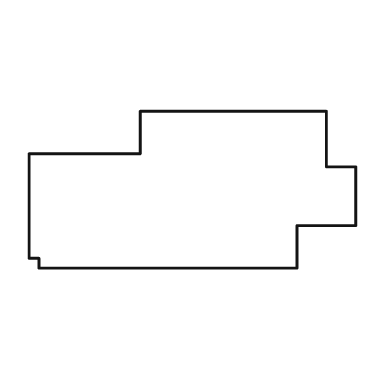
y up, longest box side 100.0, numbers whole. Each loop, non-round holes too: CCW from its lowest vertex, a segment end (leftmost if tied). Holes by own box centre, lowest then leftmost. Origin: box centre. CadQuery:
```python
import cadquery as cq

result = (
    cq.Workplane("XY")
    .moveTo(-47.0, -24.0)
    .lineTo(32.0, -24.0)
    .lineTo(32.0, -11.0)
    .lineTo(50.0, -11.0)
    .lineTo(50.0, 7.0)
    .lineTo(41.0, 7.0)
    .lineTo(41.0, 24.0)
    .lineTo(-16.0, 24.0)
    .lineTo(-16.0, 11.0)
    .lineTo(-50.0, 11.0)
    .lineTo(-50.0, -21.0)
    .lineTo(-47.0, -21.0)
    .close()
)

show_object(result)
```